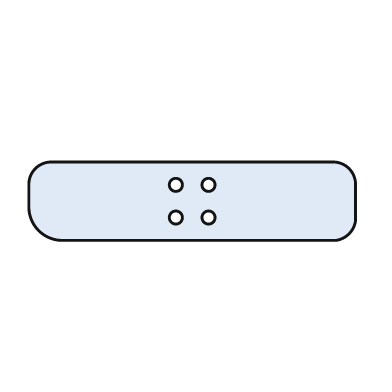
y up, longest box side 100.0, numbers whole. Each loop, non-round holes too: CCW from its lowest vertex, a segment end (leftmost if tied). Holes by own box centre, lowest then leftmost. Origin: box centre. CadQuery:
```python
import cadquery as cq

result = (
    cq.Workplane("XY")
    .moveTo(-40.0, -12.0)
    .lineTo(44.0, -12.0)
    .threePointArc((48.0, -10.0), (50.0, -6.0))
    .lineTo(50.0, 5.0)
    .threePointArc((48.0, 10.0), (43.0, 12.0))
    .lineTo(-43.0, 12.0)
    .threePointArc((-48.0, 10.0), (-50.0, 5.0))
    .lineTo(-50.0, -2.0)
    .threePointArc((-47.0, -9.0), (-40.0, -12.0))
    .close()
    .moveTo(-5.0, -5.0)
    .circle(2.0)
    .moveTo(5.0, -5.0)
    .circle(2.0)
    .moveTo(-5.0, 5.0)
    .circle(2.0)
    .moveTo(5.0, 5.0)
    .circle(2.0)
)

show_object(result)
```